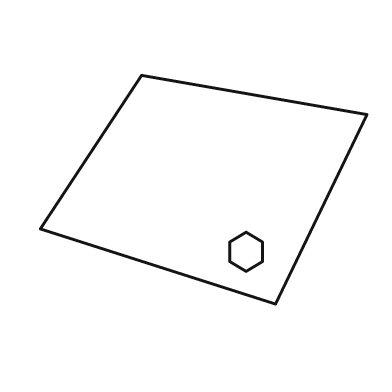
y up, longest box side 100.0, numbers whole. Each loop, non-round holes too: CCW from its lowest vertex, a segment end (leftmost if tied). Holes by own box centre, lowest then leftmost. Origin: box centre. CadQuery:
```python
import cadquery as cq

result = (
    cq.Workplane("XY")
    .moveTo(22.0, -35.0)
    .lineTo(50.0, 23.0)
    .lineTo(-19.0, 35.0)
    .lineTo(-50.0, -12.0)
    .close()
    .moveTo(13.0, -25.0)
    .lineTo(18.0, -22.0)
    .lineTo(18.0, -16.0)
    .lineTo(13.0, -13.0)
    .lineTo(8.0, -16.0)
    .lineTo(8.0, -22.0)
    .close()
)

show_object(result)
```